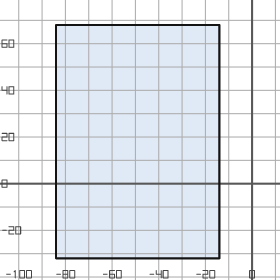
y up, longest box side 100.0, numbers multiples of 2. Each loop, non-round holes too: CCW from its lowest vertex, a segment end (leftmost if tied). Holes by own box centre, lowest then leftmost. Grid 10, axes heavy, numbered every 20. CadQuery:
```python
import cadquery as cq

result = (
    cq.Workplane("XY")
    .moveTo(-84.0, -32.0)
    .lineTo(-14.0, -32.0)
    .lineTo(-14.0, 68.0)
    .lineTo(-84.0, 68.0)
    .close()
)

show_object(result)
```